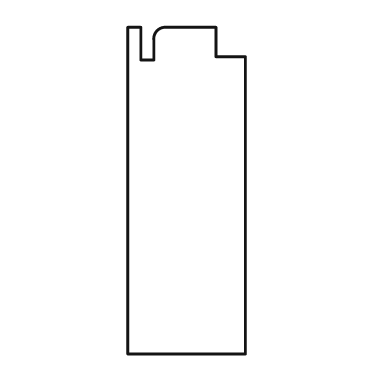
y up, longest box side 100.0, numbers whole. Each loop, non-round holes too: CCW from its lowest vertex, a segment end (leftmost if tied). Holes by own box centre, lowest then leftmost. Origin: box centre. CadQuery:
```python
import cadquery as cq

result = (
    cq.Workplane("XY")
    .moveTo(-18.0, -50.0)
    .lineTo(18.0, -50.0)
    .lineTo(18.0, 41.0)
    .lineTo(9.0, 41.0)
    .lineTo(9.0, 50.0)
    .lineTo(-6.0, 50.0)
    .threePointArc((-9.0, 49.0), (-10.0, 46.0))
    .lineTo(-10.0, 40.0)
    .lineTo(-14.0, 40.0)
    .lineTo(-14.0, 50.0)
    .lineTo(-18.0, 50.0)
    .close()
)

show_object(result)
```